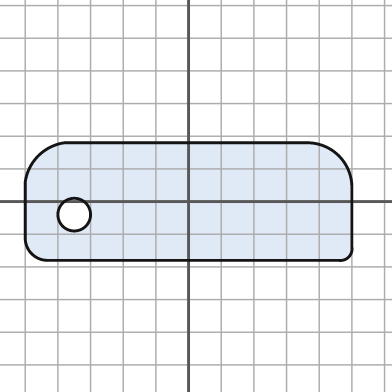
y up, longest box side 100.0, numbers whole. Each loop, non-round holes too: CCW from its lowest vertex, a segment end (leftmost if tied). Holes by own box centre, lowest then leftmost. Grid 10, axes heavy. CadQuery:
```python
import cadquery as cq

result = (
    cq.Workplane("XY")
    .moveTo(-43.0, -18.0)
    .lineTo(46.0, -18.0)
    .threePointArc((49.0, -17.0), (50.0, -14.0))
    .lineTo(50.0, 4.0)
    .threePointArc((46.0, 14.0), (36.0, 18.0))
    .lineTo(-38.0, 18.0)
    .threePointArc((-46.0, 14.0), (-50.0, 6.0))
    .lineTo(-50.0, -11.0)
    .threePointArc((-48.0, -16.0), (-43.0, -18.0))
    .close()
    .moveTo(-35.0, -4.0)
    .circle(5.0)
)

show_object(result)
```